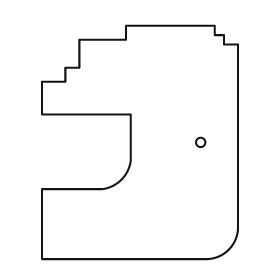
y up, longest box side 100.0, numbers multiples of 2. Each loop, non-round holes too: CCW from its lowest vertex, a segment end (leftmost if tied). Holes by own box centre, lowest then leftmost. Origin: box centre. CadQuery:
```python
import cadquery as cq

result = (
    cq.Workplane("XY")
    .moveTo(-42.0, -50.0)
    .lineTo(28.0, -50.0)
    .threePointArc((38.0, -46.0), (42.0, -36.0))
    .lineTo(42.0, 42.0)
    .lineTo(36.0, 42.0)
    .lineTo(36.0, 46.0)
    .lineTo(32.0, 46.0)
    .lineTo(32.0, 50.0)
    .lineTo(-6.0, 50.0)
    .lineTo(-6.0, 44.0)
    .lineTo(-26.0, 44.0)
    .lineTo(-26.0, 32.0)
    .lineTo(-32.0, 32.0)
    .lineTo(-32.0, 26.0)
    .lineTo(-42.0, 26.0)
    .lineTo(-42.0, 12.0)
    .lineTo(-4.0, 12.0)
    .lineTo(-4.0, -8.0)
    .threePointArc((-8.0, -16.0), (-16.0, -20.0))
    .lineTo(-42.0, -20.0)
    .close()
    .moveTo(26.0, 0.0)
    .circle(2.0)
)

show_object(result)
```